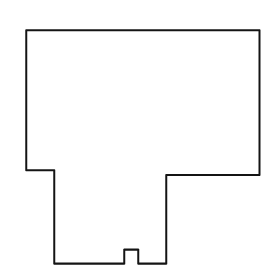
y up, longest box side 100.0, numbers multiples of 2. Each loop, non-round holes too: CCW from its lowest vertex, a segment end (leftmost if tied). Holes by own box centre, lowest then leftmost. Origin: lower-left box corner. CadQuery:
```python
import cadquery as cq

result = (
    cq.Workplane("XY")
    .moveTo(12.0, 0.0)
    .lineTo(42.0, 0.0)
    .lineTo(42.0, 6.0)
    .lineTo(48.0, 6.0)
    .lineTo(48.0, 0.0)
    .lineTo(60.0, 0.0)
    .lineTo(60.0, 38.0)
    .lineTo(100.0, 38.0)
    .lineTo(100.0, 100.0)
    .lineTo(0.0, 100.0)
    .lineTo(0.0, 40.0)
    .lineTo(12.0, 40.0)
    .close()
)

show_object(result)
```